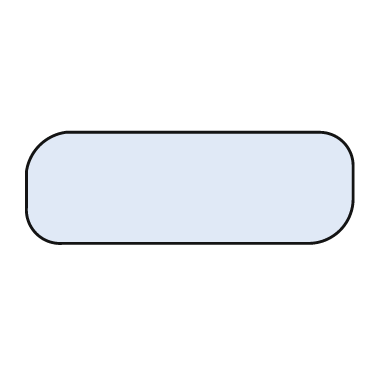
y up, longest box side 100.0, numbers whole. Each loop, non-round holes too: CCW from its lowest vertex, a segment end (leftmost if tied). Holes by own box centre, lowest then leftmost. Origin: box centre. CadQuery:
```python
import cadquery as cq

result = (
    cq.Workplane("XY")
    .moveTo(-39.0, -17.0)
    .lineTo(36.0, -17.0)
    .threePointArc((46.0, -13.0), (50.0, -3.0))
    .lineTo(50.0, 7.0)
    .threePointArc((47.0, 14.0), (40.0, 17.0))
    .lineTo(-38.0, 17.0)
    .threePointArc((-46.0, 13.0), (-50.0, 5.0))
    .lineTo(-50.0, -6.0)
    .threePointArc((-47.0, -14.0), (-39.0, -17.0))
    .close()
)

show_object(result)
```